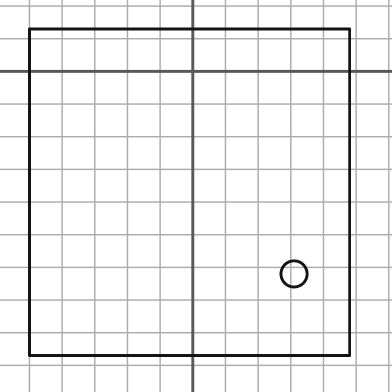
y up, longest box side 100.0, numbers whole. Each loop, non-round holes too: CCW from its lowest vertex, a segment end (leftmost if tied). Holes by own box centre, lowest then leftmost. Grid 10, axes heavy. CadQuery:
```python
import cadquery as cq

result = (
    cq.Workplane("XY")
    .moveTo(-50.0, -87.0)
    .lineTo(48.0, -87.0)
    .lineTo(48.0, 13.0)
    .lineTo(-50.0, 13.0)
    .close()
    .moveTo(31.0, -62.0)
    .circle(4.0)
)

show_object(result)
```